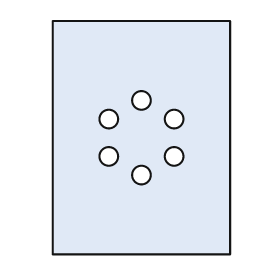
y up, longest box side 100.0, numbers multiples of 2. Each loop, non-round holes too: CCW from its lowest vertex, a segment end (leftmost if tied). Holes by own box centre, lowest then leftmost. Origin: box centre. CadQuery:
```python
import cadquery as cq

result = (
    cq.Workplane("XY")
    .moveTo(-38.0, -50.0)
    .lineTo(38.0, -50.0)
    .lineTo(38.0, 50.0)
    .lineTo(-38.0, 50.0)
    .close()
    .moveTo(0.0, -16.0)
    .circle(4.0)
    .moveTo(-14.0, -8.0)
    .circle(4.0)
    .moveTo(14.0, -8.0)
    .circle(4.0)
    .moveTo(-14.0, 8.0)
    .circle(4.0)
    .moveTo(14.0, 8.0)
    .circle(4.0)
    .moveTo(0.0, 16.0)
    .circle(4.0)
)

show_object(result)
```